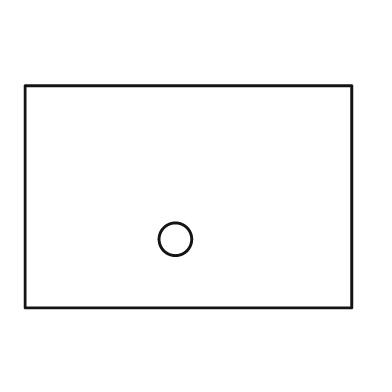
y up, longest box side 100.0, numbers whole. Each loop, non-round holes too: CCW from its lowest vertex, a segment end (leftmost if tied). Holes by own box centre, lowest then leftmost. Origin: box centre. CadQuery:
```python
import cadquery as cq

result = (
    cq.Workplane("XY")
    .moveTo(-50.0, -34.0)
    .lineTo(50.0, -34.0)
    .lineTo(50.0, 34.0)
    .lineTo(-50.0, 34.0)
    .close()
    .moveTo(-4.0, -13.0)
    .circle(5.0)
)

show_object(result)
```